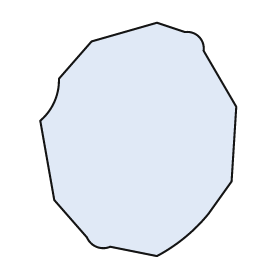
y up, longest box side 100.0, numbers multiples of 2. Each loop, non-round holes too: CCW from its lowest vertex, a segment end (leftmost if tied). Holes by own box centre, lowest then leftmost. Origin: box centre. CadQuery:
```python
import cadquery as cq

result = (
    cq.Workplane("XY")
    .moveTo(8.0, -50.0)
    .threePointArc((20.0, -42.0), (30.0, -32.0))
    .lineTo(40.0, -18.0)
    .lineTo(42.0, 14.0)
    .lineTo(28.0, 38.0)
    .threePointArc((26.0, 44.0), (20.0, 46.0))
    .lineTo(8.0, 50.0)
    .lineTo(-20.0, 42.0)
    .lineTo(-34.0, 26.0)
    .threePointArc((-36.0, 16.0), (-42.0, 8.0))
    .lineTo(-36.0, -26.0)
    .lineTo(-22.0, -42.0)
    .threePointArc((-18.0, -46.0), (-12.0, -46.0))
    .close()
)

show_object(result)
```